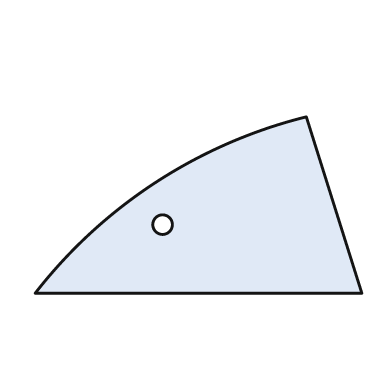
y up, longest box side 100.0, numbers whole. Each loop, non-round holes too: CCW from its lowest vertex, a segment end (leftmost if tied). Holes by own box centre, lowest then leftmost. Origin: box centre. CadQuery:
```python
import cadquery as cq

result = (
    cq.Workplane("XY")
    .moveTo(-50.0, -27.0)
    .lineTo(50.0, -27.0)
    .lineTo(33.0, 27.0)
    .threePointArc((-13.0, 7.0), (-50.0, -27.0))
    .close()
    .moveTo(-11.0, -6.0)
    .circle(3.0)
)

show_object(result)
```